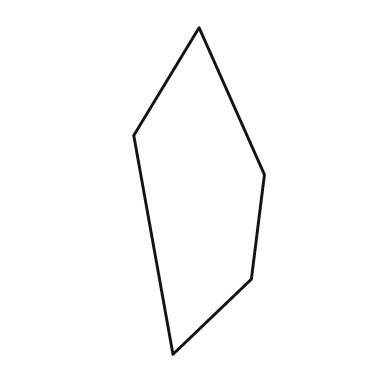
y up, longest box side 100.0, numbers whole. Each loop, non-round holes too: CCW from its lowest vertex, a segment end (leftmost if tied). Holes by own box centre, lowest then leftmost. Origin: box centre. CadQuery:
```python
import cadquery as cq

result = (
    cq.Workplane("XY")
    .moveTo(-8.0, -50.0)
    .lineTo(16.0, -27.0)
    .lineTo(20.0, 5.0)
    .lineTo(0.0, 50.0)
    .lineTo(-20.0, 17.0)
    .close()
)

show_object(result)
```